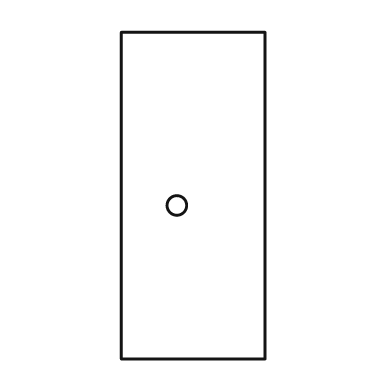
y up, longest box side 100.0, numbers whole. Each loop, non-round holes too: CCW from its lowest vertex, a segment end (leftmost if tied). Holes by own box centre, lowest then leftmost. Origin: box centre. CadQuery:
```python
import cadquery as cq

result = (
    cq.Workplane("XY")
    .moveTo(-22.0, -50.0)
    .lineTo(22.0, -50.0)
    .lineTo(22.0, 50.0)
    .lineTo(-22.0, 50.0)
    .close()
    .moveTo(-5.0, -3.0)
    .circle(3.0)
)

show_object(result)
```